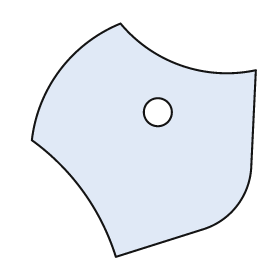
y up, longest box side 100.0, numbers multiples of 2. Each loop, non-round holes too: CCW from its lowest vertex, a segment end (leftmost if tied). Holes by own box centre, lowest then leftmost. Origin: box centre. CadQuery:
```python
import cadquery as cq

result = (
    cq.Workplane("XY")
    .moveTo(-12.0, -50.0)
    .lineTo(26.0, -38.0)
    .threePointArc((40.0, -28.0), (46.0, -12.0))
    .lineTo(48.0, 30.0)
    .threePointArc((16.0, 32.0), (-10.0, 50.0))
    .threePointArc((-36.0, 30.0), (-48.0, 0.0))
    .threePointArc((-26.0, -22.0), (-12.0, -50.0))
    .close()
    .moveTo(6.0, 12.0)
    .circle(6.0)
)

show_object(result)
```